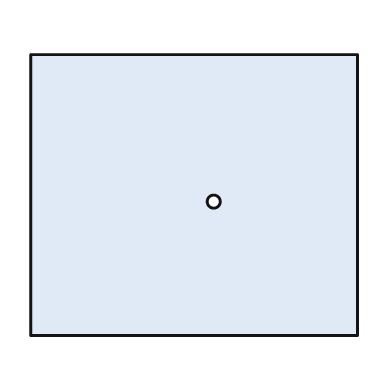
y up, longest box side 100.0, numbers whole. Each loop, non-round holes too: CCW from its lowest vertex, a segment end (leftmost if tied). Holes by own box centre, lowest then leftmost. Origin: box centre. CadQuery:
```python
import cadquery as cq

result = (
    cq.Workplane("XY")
    .moveTo(-50.0, -43.0)
    .lineTo(50.0, -43.0)
    .lineTo(50.0, 43.0)
    .lineTo(-50.0, 43.0)
    .close()
    .moveTo(6.0, -2.0)
    .circle(2.0)
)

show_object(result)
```